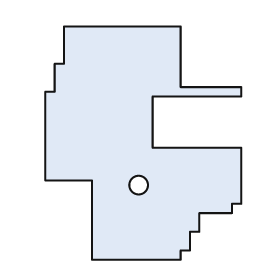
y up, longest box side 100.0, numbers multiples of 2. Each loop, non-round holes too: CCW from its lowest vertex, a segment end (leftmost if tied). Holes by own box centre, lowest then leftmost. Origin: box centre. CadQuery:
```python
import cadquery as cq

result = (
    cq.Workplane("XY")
    .moveTo(-22.0, -50.0)
    .lineTo(16.0, -50.0)
    .lineTo(16.0, -46.0)
    .lineTo(20.0, -46.0)
    .lineTo(20.0, -38.0)
    .lineTo(24.0, -38.0)
    .lineTo(24.0, -30.0)
    .lineTo(38.0, -30.0)
    .lineTo(38.0, -26.0)
    .lineTo(42.0, -26.0)
    .lineTo(42.0, -2.0)
    .lineTo(4.0, -2.0)
    .lineTo(4.0, 20.0)
    .lineTo(42.0, 20.0)
    .lineTo(42.0, 24.0)
    .lineTo(16.0, 24.0)
    .lineTo(16.0, 50.0)
    .lineTo(-34.0, 50.0)
    .lineTo(-34.0, 34.0)
    .lineTo(-38.0, 34.0)
    .lineTo(-38.0, 22.0)
    .lineTo(-42.0, 22.0)
    .lineTo(-42.0, -16.0)
    .lineTo(-22.0, -16.0)
    .close()
    .moveTo(-2.0, -18.0)
    .circle(4.0)
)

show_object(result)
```